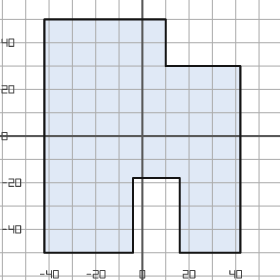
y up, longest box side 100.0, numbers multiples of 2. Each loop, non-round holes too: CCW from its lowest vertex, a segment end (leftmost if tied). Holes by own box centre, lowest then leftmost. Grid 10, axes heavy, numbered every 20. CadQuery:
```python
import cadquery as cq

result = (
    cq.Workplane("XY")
    .moveTo(-42.0, -50.0)
    .lineTo(-4.0, -50.0)
    .lineTo(-4.0, -18.0)
    .lineTo(16.0, -18.0)
    .lineTo(16.0, -50.0)
    .lineTo(42.0, -50.0)
    .lineTo(42.0, 30.0)
    .lineTo(10.0, 30.0)
    .lineTo(10.0, 50.0)
    .lineTo(-42.0, 50.0)
    .close()
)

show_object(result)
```